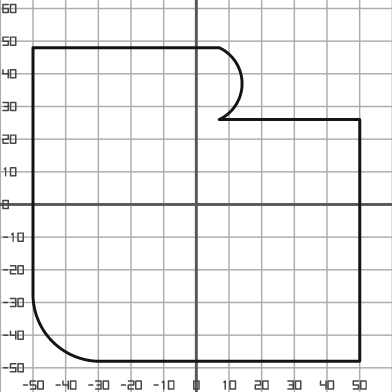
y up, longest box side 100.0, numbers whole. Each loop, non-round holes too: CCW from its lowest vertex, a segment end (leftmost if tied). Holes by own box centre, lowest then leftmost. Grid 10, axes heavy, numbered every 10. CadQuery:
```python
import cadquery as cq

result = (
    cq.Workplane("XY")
    .moveTo(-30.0, -48.0)
    .lineTo(50.0, -48.0)
    .lineTo(50.0, 26.0)
    .lineTo(7.0, 26.0)
    .threePointArc((14.0, 37.0), (7.0, 48.0))
    .lineTo(-50.0, 48.0)
    .lineTo(-50.0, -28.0)
    .threePointArc((-44.0, -42.0), (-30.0, -48.0))
    .close()
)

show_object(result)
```